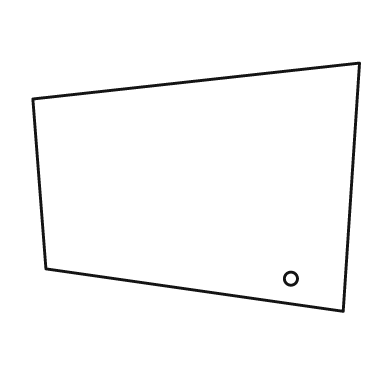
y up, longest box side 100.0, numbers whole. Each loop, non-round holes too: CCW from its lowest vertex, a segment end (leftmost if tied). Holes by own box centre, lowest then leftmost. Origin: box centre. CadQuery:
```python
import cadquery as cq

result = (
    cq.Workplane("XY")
    .moveTo(45.0, -38.0)
    .lineTo(50.0, 38.0)
    .lineTo(-50.0, 27.0)
    .lineTo(-46.0, -25.0)
    .close()
    .moveTo(29.0, -28.0)
    .circle(2.0)
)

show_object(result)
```